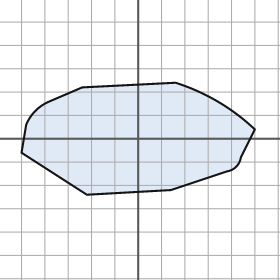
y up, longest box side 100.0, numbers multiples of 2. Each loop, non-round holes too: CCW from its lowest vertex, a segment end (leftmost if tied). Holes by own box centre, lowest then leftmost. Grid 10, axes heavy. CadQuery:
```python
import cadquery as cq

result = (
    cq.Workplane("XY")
    .moveTo(-22.0, -24.0)
    .lineTo(14.0, -22.0)
    .lineTo(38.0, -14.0)
    .threePointArc((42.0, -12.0), (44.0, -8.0))
    .lineTo(50.0, 4.0)
    .threePointArc((34.0, 16.0), (16.0, 24.0))
    .lineTo(-24.0, 22.0)
    .lineTo(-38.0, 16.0)
    .threePointArc((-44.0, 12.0), (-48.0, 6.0))
    .lineTo(-50.0, -6.0)
    .close()
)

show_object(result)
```